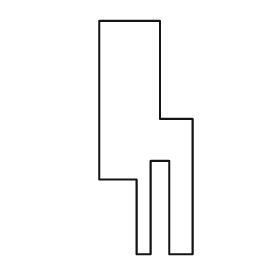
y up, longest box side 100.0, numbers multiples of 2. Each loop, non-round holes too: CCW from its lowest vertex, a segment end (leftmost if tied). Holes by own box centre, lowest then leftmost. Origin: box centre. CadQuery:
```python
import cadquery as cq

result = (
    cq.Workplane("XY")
    .moveTo(-4.0, -50.0)
    .lineTo(2.0, -50.0)
    .lineTo(2.0, -10.0)
    .lineTo(10.0, -10.0)
    .lineTo(10.0, -50.0)
    .lineTo(20.0, -50.0)
    .lineTo(20.0, 8.0)
    .lineTo(6.0, 8.0)
    .lineTo(6.0, 50.0)
    .lineTo(-20.0, 50.0)
    .lineTo(-20.0, -18.0)
    .lineTo(-4.0, -18.0)
    .close()
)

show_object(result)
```